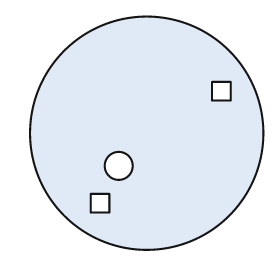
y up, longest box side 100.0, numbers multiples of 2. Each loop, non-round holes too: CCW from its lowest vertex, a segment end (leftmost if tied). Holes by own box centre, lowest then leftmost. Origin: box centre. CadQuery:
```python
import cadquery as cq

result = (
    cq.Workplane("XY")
    .moveTo(0.0, 0.0)
    .circle(50.0)
    .moveTo(-24.0, -34.0)
    .lineTo(-16.0, -34.0)
    .lineTo(-16.0, -26.0)
    .lineTo(-24.0, -26.0)
    .close()
    .moveTo(-12.0, -14.0)
    .circle(6.0)
    .moveTo(28.0, 14.0)
    .lineTo(36.0, 14.0)
    .lineTo(36.0, 22.0)
    .lineTo(28.0, 22.0)
    .close()
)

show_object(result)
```